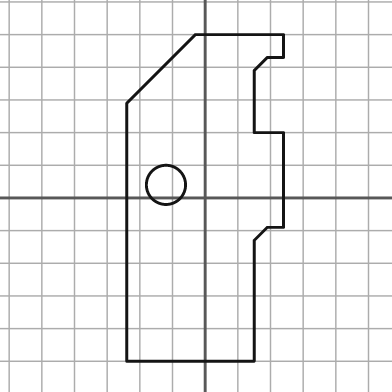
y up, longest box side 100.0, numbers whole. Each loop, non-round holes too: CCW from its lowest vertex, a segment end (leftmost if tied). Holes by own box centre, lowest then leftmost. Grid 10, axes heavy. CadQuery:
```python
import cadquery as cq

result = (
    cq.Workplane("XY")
    .moveTo(-24.0, -50.0)
    .lineTo(15.0, -50.0)
    .lineTo(15.0, -13.0)
    .lineTo(19.0, -9.0)
    .lineTo(24.0, -9.0)
    .lineTo(24.0, 20.0)
    .lineTo(15.0, 20.0)
    .lineTo(15.0, 39.0)
    .lineTo(19.0, 43.0)
    .lineTo(24.0, 43.0)
    .lineTo(24.0, 50.0)
    .lineTo(-3.0, 50.0)
    .lineTo(-24.0, 29.0)
    .close()
    .moveTo(-12.0, 4.0)
    .circle(6.0)
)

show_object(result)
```